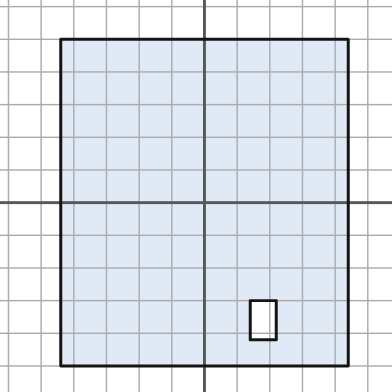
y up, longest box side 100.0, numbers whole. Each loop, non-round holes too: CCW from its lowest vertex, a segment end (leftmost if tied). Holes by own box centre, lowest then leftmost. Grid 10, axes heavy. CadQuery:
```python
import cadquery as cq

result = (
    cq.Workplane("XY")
    .moveTo(-44.0, -50.0)
    .lineTo(44.0, -50.0)
    .lineTo(44.0, 50.0)
    .lineTo(-44.0, 50.0)
    .close()
    .moveTo(14.0, -42.0)
    .lineTo(22.0, -42.0)
    .lineTo(22.0, -30.0)
    .lineTo(14.0, -30.0)
    .close()
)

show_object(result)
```